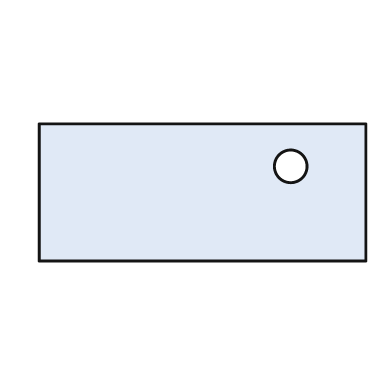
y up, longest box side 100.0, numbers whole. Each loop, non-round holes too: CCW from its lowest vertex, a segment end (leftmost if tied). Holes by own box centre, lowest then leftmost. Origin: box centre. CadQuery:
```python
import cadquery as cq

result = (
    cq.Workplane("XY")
    .moveTo(-50.0, -21.0)
    .lineTo(50.0, -21.0)
    .lineTo(50.0, 21.0)
    .lineTo(-50.0, 21.0)
    .close()
    .moveTo(27.0, 8.0)
    .circle(5.0)
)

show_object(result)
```